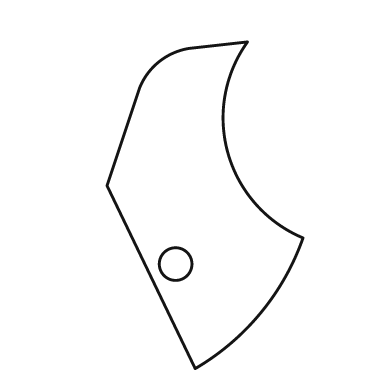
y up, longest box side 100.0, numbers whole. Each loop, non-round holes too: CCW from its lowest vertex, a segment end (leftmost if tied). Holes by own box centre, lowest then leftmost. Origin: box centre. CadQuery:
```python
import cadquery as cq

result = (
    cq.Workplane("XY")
    .moveTo(-3.0, -50.0)
    .threePointArc((17.0, -33.0), (30.0, -10.0))
    .threePointArc((7.0, 16.0), (13.0, 50.0))
    .lineTo(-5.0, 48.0)
    .threePointArc((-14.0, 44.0), (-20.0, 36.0))
    .lineTo(-30.0, 6.0)
    .close()
    .moveTo(-9.0, -18.0)
    .circle(5.0)
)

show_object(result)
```